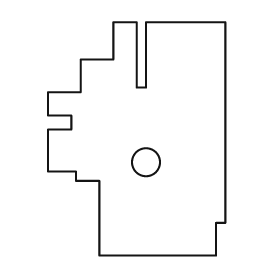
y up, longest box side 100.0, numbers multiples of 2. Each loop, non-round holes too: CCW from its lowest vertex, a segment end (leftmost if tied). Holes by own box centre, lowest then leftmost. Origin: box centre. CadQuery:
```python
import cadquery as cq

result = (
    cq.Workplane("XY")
    .moveTo(-16.0, -50.0)
    .lineTo(34.0, -50.0)
    .lineTo(34.0, -36.0)
    .lineTo(38.0, -36.0)
    .lineTo(38.0, 50.0)
    .lineTo(4.0, 50.0)
    .lineTo(4.0, 22.0)
    .lineTo(0.0, 22.0)
    .lineTo(0.0, 50.0)
    .lineTo(-10.0, 50.0)
    .lineTo(-10.0, 34.0)
    .lineTo(-24.0, 34.0)
    .lineTo(-24.0, 20.0)
    .lineTo(-38.0, 20.0)
    .lineTo(-38.0, 10.0)
    .lineTo(-28.0, 10.0)
    .lineTo(-28.0, 4.0)
    .lineTo(-38.0, 4.0)
    .lineTo(-38.0, -14.0)
    .lineTo(-26.0, -14.0)
    .lineTo(-26.0, -18.0)
    .lineTo(-16.0, -18.0)
    .close()
    .moveTo(4.0, -10.0)
    .circle(6.0)
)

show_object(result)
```